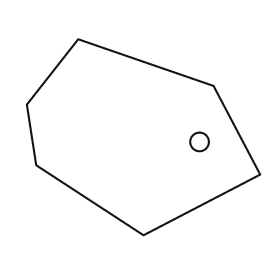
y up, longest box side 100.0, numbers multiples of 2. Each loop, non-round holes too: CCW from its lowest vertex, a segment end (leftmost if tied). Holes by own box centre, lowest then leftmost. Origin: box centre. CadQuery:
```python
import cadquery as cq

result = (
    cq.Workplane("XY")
    .moveTo(0.0, -42.0)
    .lineTo(50.0, -16.0)
    .lineTo(30.0, 22.0)
    .lineTo(-28.0, 42.0)
    .lineTo(-50.0, 14.0)
    .lineTo(-46.0, -12.0)
    .close()
    .moveTo(24.0, -2.0)
    .circle(4.0)
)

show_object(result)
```